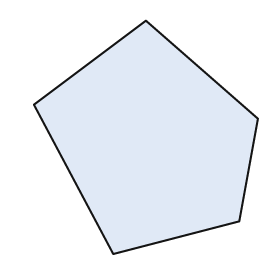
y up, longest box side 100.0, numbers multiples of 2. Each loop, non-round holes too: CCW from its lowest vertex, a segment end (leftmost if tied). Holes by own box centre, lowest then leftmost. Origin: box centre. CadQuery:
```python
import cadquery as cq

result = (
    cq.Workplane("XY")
    .moveTo(-14.0, -50.0)
    .lineTo(40.0, -36.0)
    .lineTo(48.0, 8.0)
    .lineTo(0.0, 50.0)
    .lineTo(-48.0, 14.0)
    .close()
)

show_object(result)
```